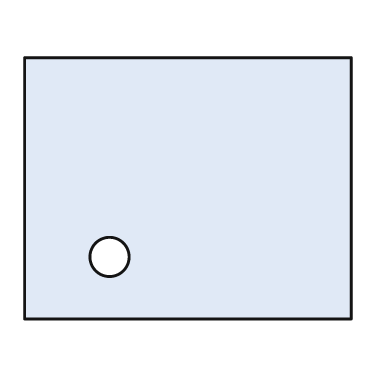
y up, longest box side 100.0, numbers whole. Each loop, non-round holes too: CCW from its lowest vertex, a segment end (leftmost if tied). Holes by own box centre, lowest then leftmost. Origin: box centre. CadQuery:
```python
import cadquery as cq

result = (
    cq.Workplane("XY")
    .moveTo(-50.0, -40.0)
    .lineTo(50.0, -40.0)
    .lineTo(50.0, 40.0)
    .lineTo(-50.0, 40.0)
    .close()
    .moveTo(-24.0, -21.0)
    .circle(6.0)
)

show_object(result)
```